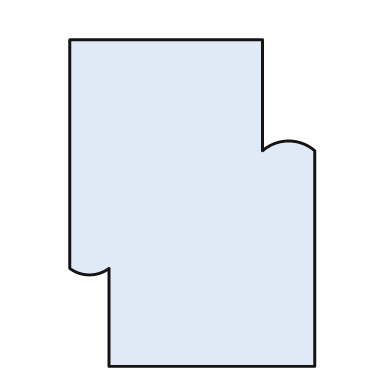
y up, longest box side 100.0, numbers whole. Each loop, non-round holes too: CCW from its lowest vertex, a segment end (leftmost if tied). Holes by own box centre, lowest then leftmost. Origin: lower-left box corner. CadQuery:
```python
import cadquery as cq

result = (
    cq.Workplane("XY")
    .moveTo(12.0, 0.0)
    .lineTo(75.0, 0.0)
    .lineTo(75.0, 66.0)
    .threePointArc((67.0, 69.0), (59.0, 66.0))
    .lineTo(59.0, 100.0)
    .lineTo(0.0, 100.0)
    .lineTo(0.0, 30.0)
    .threePointArc((6.0, 28.0), (12.0, 30.0))
    .close()
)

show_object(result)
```